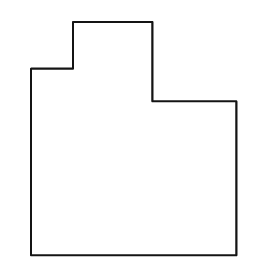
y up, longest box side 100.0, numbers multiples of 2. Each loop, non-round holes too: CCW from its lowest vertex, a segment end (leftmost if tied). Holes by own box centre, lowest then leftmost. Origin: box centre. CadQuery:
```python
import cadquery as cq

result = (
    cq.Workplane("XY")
    .moveTo(-44.0, -50.0)
    .lineTo(44.0, -50.0)
    .lineTo(44.0, 16.0)
    .lineTo(8.0, 16.0)
    .lineTo(8.0, 50.0)
    .lineTo(-26.0, 50.0)
    .lineTo(-26.0, 30.0)
    .lineTo(-44.0, 30.0)
    .close()
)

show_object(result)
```